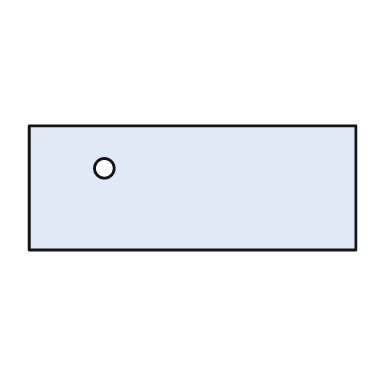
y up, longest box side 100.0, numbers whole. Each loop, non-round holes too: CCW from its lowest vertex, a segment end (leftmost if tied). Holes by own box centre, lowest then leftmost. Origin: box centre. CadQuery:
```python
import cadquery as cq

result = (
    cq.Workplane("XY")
    .moveTo(-50.0, -19.0)
    .lineTo(50.0, -19.0)
    .lineTo(50.0, 19.0)
    .lineTo(-50.0, 19.0)
    .close()
    .moveTo(-27.0, 6.0)
    .circle(3.0)
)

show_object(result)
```